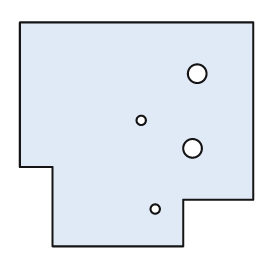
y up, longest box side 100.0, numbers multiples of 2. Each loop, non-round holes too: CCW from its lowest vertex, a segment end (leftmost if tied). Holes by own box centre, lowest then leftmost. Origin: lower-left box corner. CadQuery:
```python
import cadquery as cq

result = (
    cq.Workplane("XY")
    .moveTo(14.0, 0.0)
    .lineTo(70.0, 0.0)
    .lineTo(70.0, 20.0)
    .lineTo(100.0, 20.0)
    .lineTo(100.0, 96.0)
    .lineTo(0.0, 96.0)
    .lineTo(0.0, 34.0)
    .lineTo(14.0, 34.0)
    .close()
    .moveTo(58.0, 16.0)
    .circle(2.0)
    .moveTo(74.0, 42.0)
    .circle(4.0)
    .moveTo(52.0, 54.0)
    .circle(2.0)
    .moveTo(76.0, 74.0)
    .circle(4.0)
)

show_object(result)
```